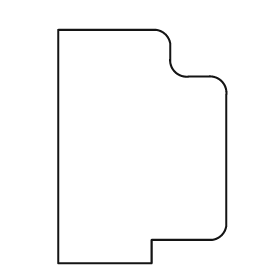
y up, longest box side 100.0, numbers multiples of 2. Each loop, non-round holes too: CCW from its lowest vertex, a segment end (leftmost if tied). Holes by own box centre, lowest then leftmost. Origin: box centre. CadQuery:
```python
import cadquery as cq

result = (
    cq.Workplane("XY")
    .moveTo(-36.0, -50.0)
    .lineTo(4.0, -50.0)
    .lineTo(4.0, -40.0)
    .lineTo(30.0, -40.0)
    .threePointArc((34.0, -38.0), (36.0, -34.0))
    .lineTo(36.0, 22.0)
    .threePointArc((34.0, 28.0), (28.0, 30.0))
    .lineTo(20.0, 30.0)
    .threePointArc((14.0, 32.0), (12.0, 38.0))
    .lineTo(12.0, 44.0)
    .threePointArc((10.0, 48.0), (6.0, 50.0))
    .lineTo(-36.0, 50.0)
    .close()
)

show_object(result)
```